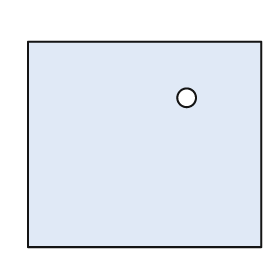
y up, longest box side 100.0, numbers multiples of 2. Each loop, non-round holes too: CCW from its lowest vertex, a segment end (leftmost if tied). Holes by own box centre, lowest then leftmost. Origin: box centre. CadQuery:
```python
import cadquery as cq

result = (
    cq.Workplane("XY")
    .moveTo(-50.0, -44.0)
    .lineTo(50.0, -44.0)
    .lineTo(50.0, 44.0)
    .lineTo(-50.0, 44.0)
    .close()
    .moveTo(18.0, 20.0)
    .circle(4.0)
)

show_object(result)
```